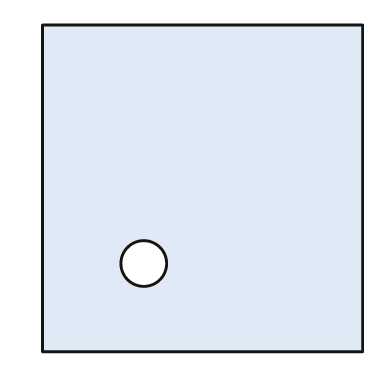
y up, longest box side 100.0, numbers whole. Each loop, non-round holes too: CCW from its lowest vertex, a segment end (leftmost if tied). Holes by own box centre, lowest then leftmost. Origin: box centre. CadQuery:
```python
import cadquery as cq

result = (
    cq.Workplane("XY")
    .moveTo(-49.0, -50.0)
    .lineTo(49.0, -50.0)
    .lineTo(49.0, 50.0)
    .lineTo(-49.0, 50.0)
    .close()
    .moveTo(-18.0, -23.0)
    .circle(7.0)
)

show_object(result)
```